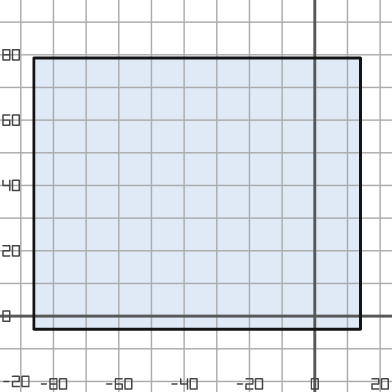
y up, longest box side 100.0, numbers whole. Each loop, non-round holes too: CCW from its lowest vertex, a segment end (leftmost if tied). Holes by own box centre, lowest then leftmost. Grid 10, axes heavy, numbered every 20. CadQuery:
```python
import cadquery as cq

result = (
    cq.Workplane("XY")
    .moveTo(-86.0, -4.0)
    .lineTo(14.0, -4.0)
    .lineTo(14.0, 79.0)
    .lineTo(-86.0, 79.0)
    .close()
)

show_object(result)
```